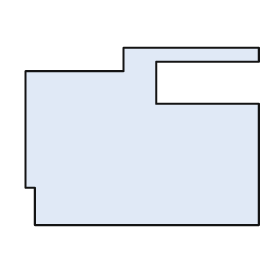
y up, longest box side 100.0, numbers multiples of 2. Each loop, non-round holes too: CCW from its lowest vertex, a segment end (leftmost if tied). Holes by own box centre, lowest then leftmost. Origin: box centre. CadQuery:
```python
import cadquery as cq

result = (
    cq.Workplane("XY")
    .moveTo(-46.0, -38.0)
    .lineTo(50.0, -38.0)
    .lineTo(50.0, 14.0)
    .lineTo(6.0, 14.0)
    .lineTo(6.0, 32.0)
    .lineTo(50.0, 32.0)
    .lineTo(50.0, 38.0)
    .lineTo(-8.0, 38.0)
    .lineTo(-8.0, 28.0)
    .lineTo(-50.0, 28.0)
    .lineTo(-50.0, -22.0)
    .lineTo(-46.0, -22.0)
    .close()
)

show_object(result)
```